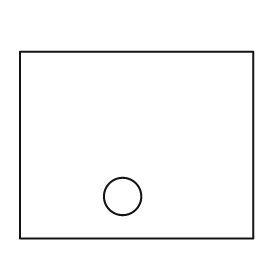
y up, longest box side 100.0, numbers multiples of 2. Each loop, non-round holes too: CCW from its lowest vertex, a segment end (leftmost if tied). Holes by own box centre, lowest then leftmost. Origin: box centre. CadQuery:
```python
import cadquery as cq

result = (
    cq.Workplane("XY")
    .moveTo(-50.0, -40.0)
    .lineTo(50.0, -40.0)
    .lineTo(50.0, 40.0)
    .lineTo(-50.0, 40.0)
    .close()
    .moveTo(-6.0, -22.0)
    .circle(8.0)
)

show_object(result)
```